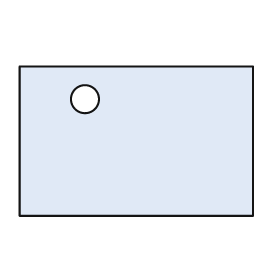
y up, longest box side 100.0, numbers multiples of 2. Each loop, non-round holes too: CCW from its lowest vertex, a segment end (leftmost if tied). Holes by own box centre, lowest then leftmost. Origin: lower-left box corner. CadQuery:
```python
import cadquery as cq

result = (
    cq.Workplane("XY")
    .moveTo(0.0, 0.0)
    .lineTo(100.0, 0.0)
    .lineTo(100.0, 64.0)
    .lineTo(0.0, 64.0)
    .close()
    .moveTo(28.0, 50.0)
    .circle(6.0)
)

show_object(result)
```